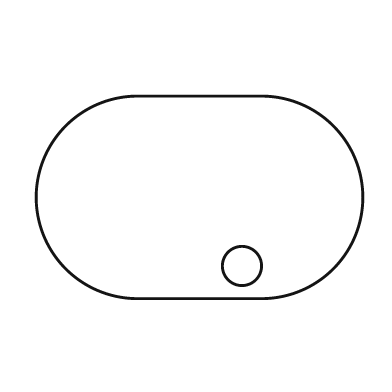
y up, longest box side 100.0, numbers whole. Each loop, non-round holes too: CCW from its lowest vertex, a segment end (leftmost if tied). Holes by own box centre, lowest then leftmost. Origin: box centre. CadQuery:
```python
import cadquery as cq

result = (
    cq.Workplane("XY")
    .moveTo(-19.0, -31.0)
    .lineTo(19.0, -31.0)
    .threePointArc((50.0, 0.0), (19.0, 31.0))
    .lineTo(-19.0, 31.0)
    .threePointArc((-50.0, 0.0), (-19.0, -31.0))
    .close()
    .moveTo(13.0, -21.0)
    .circle(6.0)
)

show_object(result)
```